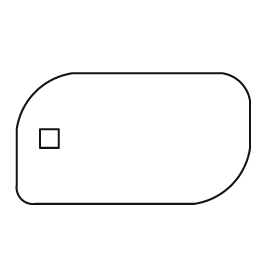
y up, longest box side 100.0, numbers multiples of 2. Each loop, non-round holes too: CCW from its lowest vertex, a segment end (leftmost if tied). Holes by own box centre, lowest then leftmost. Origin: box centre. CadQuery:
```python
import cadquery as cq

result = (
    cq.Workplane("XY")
    .moveTo(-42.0, -28.0)
    .lineTo(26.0, -28.0)
    .threePointArc((42.0, -20.0), (50.0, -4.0))
    .lineTo(50.0, 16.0)
    .threePointArc((46.0, 24.0), (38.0, 28.0))
    .lineTo(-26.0, 28.0)
    .threePointArc((-42.0, 20.0), (-50.0, 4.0))
    .lineTo(-50.0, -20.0)
    .threePointArc((-48.0, -26.0), (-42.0, -28.0))
    .close()
    .moveTo(-40.0, -4.0)
    .lineTo(-32.0, -4.0)
    .lineTo(-32.0, 4.0)
    .lineTo(-40.0, 4.0)
    .close()
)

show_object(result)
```